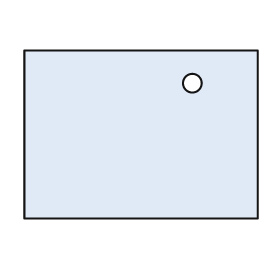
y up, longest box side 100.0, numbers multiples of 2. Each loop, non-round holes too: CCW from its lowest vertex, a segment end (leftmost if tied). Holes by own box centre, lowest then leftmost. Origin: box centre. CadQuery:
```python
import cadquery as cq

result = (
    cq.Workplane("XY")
    .moveTo(-50.0, -36.0)
    .lineTo(50.0, -36.0)
    .lineTo(50.0, 36.0)
    .lineTo(-50.0, 36.0)
    .close()
    .moveTo(22.0, 22.0)
    .circle(4.0)
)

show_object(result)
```